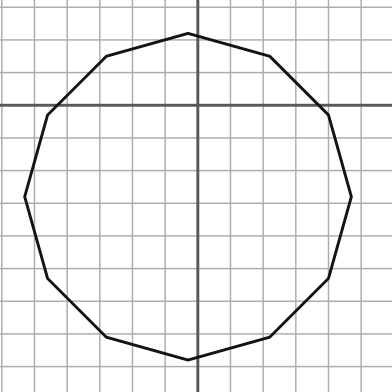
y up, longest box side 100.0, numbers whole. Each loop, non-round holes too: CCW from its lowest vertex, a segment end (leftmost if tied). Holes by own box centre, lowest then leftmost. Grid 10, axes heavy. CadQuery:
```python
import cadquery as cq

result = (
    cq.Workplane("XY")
    .moveTo(-3.0, -78.0)
    .lineTo(22.0, -71.0)
    .lineTo(40.0, -53.0)
    .lineTo(47.0, -28.0)
    .lineTo(40.0, -3.0)
    .lineTo(22.0, 15.0)
    .lineTo(-3.0, 22.0)
    .lineTo(-28.0, 15.0)
    .lineTo(-46.0, -3.0)
    .lineTo(-53.0, -28.0)
    .lineTo(-46.0, -53.0)
    .lineTo(-28.0, -71.0)
    .close()
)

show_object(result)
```